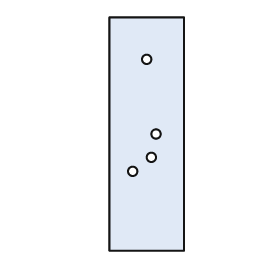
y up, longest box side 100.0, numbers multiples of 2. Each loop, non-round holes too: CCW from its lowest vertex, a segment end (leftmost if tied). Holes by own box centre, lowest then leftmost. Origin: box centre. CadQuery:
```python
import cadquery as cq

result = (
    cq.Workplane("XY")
    .moveTo(-16.0, -50.0)
    .lineTo(16.0, -50.0)
    .lineTo(16.0, 50.0)
    .lineTo(-16.0, 50.0)
    .close()
    .moveTo(-6.0, -16.0)
    .circle(2.0)
    .moveTo(2.0, -10.0)
    .circle(2.0)
    .moveTo(4.0, 0.0)
    .circle(2.0)
    .moveTo(0.0, 32.0)
    .circle(2.0)
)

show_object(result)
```